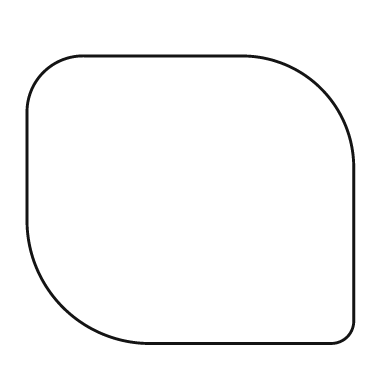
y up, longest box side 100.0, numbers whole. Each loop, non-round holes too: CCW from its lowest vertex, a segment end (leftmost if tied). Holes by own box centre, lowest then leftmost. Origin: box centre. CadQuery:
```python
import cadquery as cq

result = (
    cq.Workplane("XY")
    .moveTo(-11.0, -44.0)
    .lineTo(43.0, -44.0)
    .threePointArc((48.0, -42.0), (50.0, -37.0))
    .lineTo(50.0, 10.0)
    .threePointArc((40.0, 34.0), (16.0, 44.0))
    .lineTo(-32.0, 44.0)
    .threePointArc((-45.0, 39.0), (-50.0, 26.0))
    .lineTo(-50.0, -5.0)
    .threePointArc((-39.0, -33.0), (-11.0, -44.0))
    .close()
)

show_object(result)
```